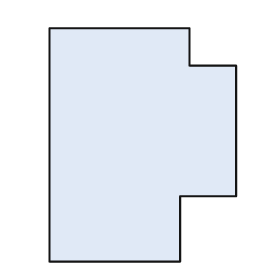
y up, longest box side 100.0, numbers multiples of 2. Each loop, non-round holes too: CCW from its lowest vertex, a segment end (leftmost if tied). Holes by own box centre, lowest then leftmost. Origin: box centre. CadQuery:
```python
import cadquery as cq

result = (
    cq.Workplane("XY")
    .moveTo(-40.0, -50.0)
    .lineTo(16.0, -50.0)
    .lineTo(16.0, -22.0)
    .lineTo(40.0, -22.0)
    .lineTo(40.0, 34.0)
    .lineTo(20.0, 34.0)
    .lineTo(20.0, 50.0)
    .lineTo(-40.0, 50.0)
    .close()
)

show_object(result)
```